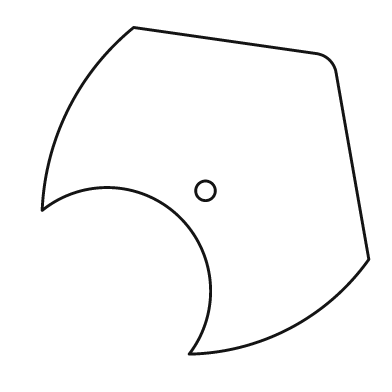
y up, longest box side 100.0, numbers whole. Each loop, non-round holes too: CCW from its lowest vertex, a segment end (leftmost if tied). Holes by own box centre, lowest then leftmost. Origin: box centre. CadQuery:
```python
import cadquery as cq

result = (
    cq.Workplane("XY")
    .moveTo(-5.0, -50.0)
    .threePointArc((26.0, -42.0), (50.0, -21.0))
    .lineTo(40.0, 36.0)
    .threePointArc((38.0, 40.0), (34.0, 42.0))
    .lineTo(-22.0, 50.0)
    .threePointArc((-42.0, 25.0), (-50.0, -6.0))
    .threePointArc((-8.0, -8.0), (-5.0, -50.0))
    .close()
    .moveTo(0.0, 0.0)
    .circle(3.0)
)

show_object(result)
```